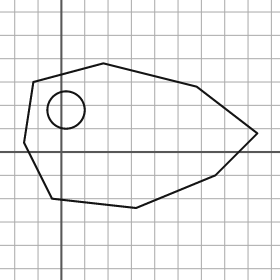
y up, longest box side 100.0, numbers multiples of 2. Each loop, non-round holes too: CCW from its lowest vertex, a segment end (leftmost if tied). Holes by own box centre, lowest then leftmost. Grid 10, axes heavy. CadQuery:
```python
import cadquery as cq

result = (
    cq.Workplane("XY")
    .moveTo(32.0, -24.0)
    .lineTo(66.0, -10.0)
    .lineTo(84.0, 8.0)
    .lineTo(58.0, 28.0)
    .lineTo(18.0, 38.0)
    .lineTo(-12.0, 30.0)
    .lineTo(-16.0, 4.0)
    .lineTo(-4.0, -20.0)
    .close()
    .moveTo(2.0, 18.0)
    .circle(8.0)
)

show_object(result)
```